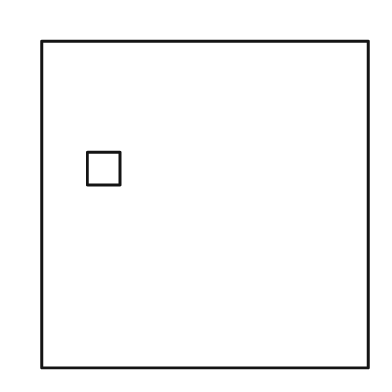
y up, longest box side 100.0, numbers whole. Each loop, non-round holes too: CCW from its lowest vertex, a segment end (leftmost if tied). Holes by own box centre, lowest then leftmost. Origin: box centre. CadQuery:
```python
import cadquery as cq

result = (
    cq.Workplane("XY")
    .moveTo(-50.0, -50.0)
    .lineTo(50.0, -50.0)
    .lineTo(50.0, 50.0)
    .lineTo(-50.0, 50.0)
    .close()
    .moveTo(-36.0, 6.0)
    .lineTo(-26.0, 6.0)
    .lineTo(-26.0, 16.0)
    .lineTo(-36.0, 16.0)
    .close()
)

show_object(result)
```